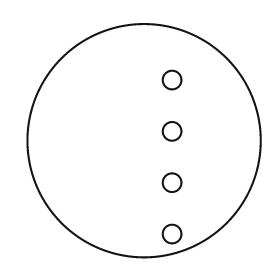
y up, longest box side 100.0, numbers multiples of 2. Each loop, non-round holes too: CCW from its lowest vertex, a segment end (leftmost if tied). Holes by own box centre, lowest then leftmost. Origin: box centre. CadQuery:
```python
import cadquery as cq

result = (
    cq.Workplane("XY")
    .moveTo(0.0, 0.0)
    .circle(50.0)
    .moveTo(12.0, -40.0)
    .circle(4.0)
    .moveTo(12.0, -18.0)
    .circle(4.0)
    .moveTo(12.0, 4.0)
    .circle(4.0)
    .moveTo(12.0, 26.0)
    .circle(4.0)
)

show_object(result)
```